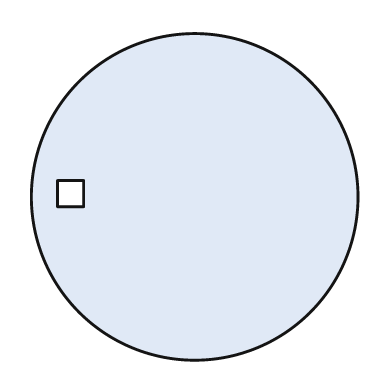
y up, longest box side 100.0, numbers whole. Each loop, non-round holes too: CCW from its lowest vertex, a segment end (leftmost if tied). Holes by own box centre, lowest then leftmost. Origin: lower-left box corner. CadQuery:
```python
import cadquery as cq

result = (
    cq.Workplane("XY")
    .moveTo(50.0, 50.0)
    .circle(50.0)
    .moveTo(8.0, 47.0)
    .lineTo(16.0, 47.0)
    .lineTo(16.0, 55.0)
    .lineTo(8.0, 55.0)
    .close()
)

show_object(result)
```